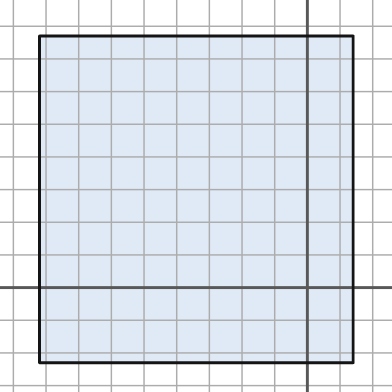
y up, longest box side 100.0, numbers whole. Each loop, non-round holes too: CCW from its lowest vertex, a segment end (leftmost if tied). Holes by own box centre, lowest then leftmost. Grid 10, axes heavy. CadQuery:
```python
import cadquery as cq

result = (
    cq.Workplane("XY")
    .moveTo(-82.0, -23.0)
    .lineTo(14.0, -23.0)
    .lineTo(14.0, 77.0)
    .lineTo(-82.0, 77.0)
    .close()
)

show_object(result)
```